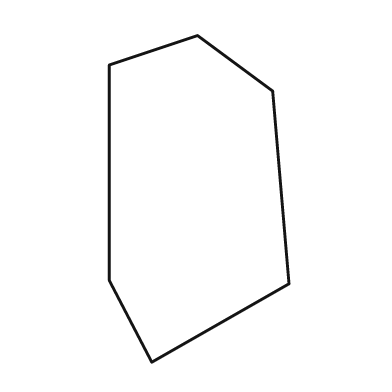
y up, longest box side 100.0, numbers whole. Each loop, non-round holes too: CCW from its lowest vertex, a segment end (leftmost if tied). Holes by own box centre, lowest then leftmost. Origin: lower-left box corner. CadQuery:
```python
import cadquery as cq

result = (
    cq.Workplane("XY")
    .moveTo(13.0, 0.0)
    .lineTo(55.0, 24.0)
    .lineTo(50.0, 83.0)
    .lineTo(27.0, 100.0)
    .lineTo(0.0, 91.0)
    .lineTo(0.0, 25.0)
    .close()
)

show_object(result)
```